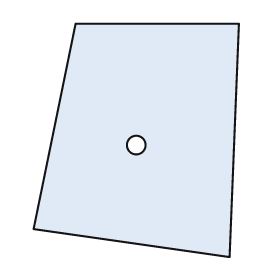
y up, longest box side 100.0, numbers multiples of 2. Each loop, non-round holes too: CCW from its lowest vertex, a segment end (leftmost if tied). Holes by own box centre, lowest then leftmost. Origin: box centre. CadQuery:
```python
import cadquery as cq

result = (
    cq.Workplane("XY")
    .moveTo(40.0, -50.0)
    .lineTo(44.0, 50.0)
    .lineTo(-26.0, 50.0)
    .lineTo(-44.0, -38.0)
    .close()
    .moveTo(0.0, -2.0)
    .circle(4.0)
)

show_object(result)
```